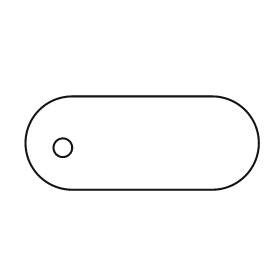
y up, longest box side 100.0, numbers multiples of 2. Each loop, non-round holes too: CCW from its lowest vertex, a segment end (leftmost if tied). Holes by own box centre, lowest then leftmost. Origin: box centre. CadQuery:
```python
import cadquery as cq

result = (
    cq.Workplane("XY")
    .moveTo(-30.0, -20.0)
    .lineTo(30.0, -20.0)
    .threePointArc((50.0, 0.0), (30.0, 20.0))
    .lineTo(-30.0, 20.0)
    .threePointArc((-50.0, 0.0), (-30.0, -20.0))
    .close()
    .moveTo(-34.0, -2.0)
    .circle(4.0)
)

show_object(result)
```